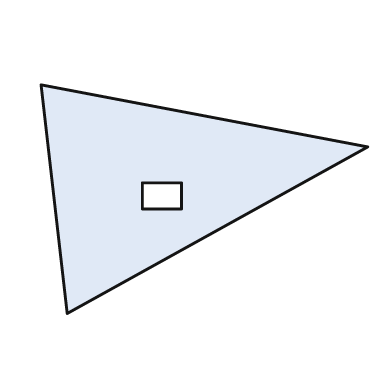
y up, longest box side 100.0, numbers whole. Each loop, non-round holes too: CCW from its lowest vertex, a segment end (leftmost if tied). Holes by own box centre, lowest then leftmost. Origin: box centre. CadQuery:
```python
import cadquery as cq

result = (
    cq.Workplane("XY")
    .moveTo(-42.0, -35.0)
    .lineTo(50.0, 16.0)
    .lineTo(-50.0, 35.0)
    .close()
    .moveTo(-19.0, -3.0)
    .lineTo(-7.0, -3.0)
    .lineTo(-7.0, 5.0)
    .lineTo(-19.0, 5.0)
    .close()
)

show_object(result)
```